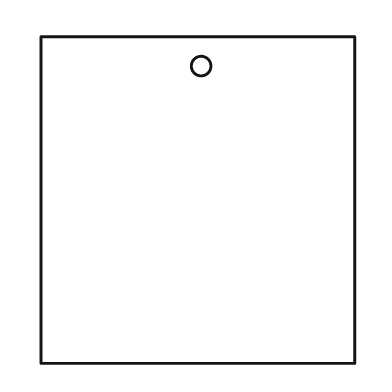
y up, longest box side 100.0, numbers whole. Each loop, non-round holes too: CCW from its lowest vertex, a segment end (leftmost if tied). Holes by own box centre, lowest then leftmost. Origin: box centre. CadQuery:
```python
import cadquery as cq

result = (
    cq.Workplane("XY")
    .moveTo(-48.0, -50.0)
    .lineTo(48.0, -50.0)
    .lineTo(48.0, 50.0)
    .lineTo(-48.0, 50.0)
    .close()
    .moveTo(1.0, 41.0)
    .circle(3.0)
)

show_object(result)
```